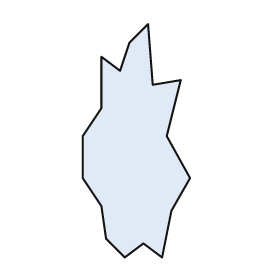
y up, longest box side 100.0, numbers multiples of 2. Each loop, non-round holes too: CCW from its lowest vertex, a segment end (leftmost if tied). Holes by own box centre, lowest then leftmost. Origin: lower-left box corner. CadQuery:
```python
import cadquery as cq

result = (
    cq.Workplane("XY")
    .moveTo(18.0, 0.0)
    .lineTo(26.0, 6.0)
    .lineTo(34.0, 0.0)
    .lineTo(38.0, 20.0)
    .lineTo(46.0, 34.0)
    .lineTo(36.0, 52.0)
    .lineTo(42.0, 76.0)
    .lineTo(30.0, 74.0)
    .lineTo(28.0, 100.0)
    .lineTo(20.0, 92.0)
    .lineTo(16.0, 80.0)
    .lineTo(8.0, 86.0)
    .lineTo(8.0, 64.0)
    .lineTo(0.0, 52.0)
    .lineTo(0.0, 34.0)
    .lineTo(8.0, 22.0)
    .lineTo(10.0, 8.0)
    .close()
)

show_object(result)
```